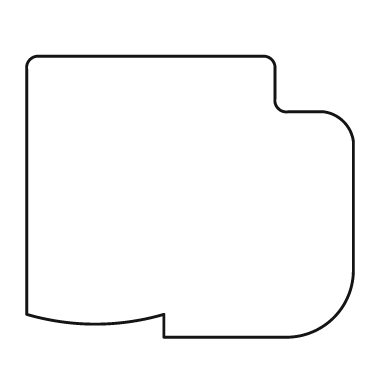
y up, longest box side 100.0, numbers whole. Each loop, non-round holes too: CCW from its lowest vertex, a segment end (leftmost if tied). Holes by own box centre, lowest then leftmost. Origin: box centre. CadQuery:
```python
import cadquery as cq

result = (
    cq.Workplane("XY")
    .moveTo(-8.0, -43.0)
    .lineTo(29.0, -43.0)
    .threePointArc((44.0, -37.0), (50.0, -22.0))
    .lineTo(50.0, 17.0)
    .threePointArc((47.0, 23.0), (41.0, 26.0))
    .lineTo(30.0, 26.0)
    .threePointArc((27.0, 27.0), (26.0, 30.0))
    .lineTo(26.0, 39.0)
    .threePointArc((25.0, 42.0), (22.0, 43.0))
    .lineTo(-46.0, 43.0)
    .threePointArc((-49.0, 42.0), (-50.0, 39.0))
    .lineTo(-50.0, -36.0)
    .threePointArc((-29.0, -39.0), (-8.0, -36.0))
    .close()
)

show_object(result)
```